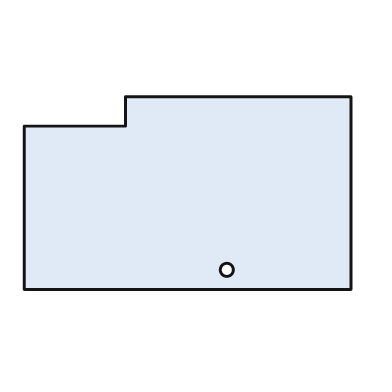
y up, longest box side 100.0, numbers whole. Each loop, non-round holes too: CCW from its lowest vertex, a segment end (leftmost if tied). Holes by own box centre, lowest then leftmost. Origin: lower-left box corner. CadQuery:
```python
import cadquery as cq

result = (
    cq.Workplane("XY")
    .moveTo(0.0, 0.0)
    .lineTo(100.0, 0.0)
    .lineTo(100.0, 59.0)
    .lineTo(31.0, 59.0)
    .lineTo(31.0, 50.0)
    .lineTo(0.0, 50.0)
    .close()
    .moveTo(62.0, 6.0)
    .circle(2.0)
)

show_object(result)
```